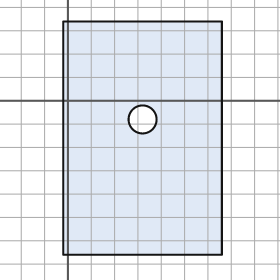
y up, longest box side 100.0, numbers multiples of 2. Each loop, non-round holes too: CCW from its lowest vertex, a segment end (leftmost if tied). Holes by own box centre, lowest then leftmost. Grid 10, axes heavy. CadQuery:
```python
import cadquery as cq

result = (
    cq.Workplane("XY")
    .moveTo(-2.0, -66.0)
    .lineTo(66.0, -66.0)
    .lineTo(66.0, 34.0)
    .lineTo(-2.0, 34.0)
    .close()
    .moveTo(32.0, -8.0)
    .circle(6.0)
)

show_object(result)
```